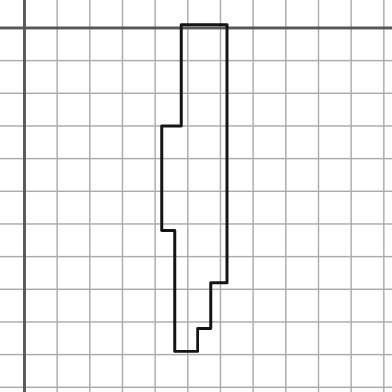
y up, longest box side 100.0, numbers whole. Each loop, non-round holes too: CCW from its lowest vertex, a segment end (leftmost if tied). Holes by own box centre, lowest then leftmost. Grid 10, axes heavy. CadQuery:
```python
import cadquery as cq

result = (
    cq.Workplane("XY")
    .moveTo(46.0, -99.0)
    .lineTo(53.0, -99.0)
    .lineTo(53.0, -92.0)
    .lineTo(57.0, -92.0)
    .lineTo(57.0, -78.0)
    .lineTo(62.0, -78.0)
    .lineTo(62.0, 1.0)
    .lineTo(48.0, 1.0)
    .lineTo(48.0, -30.0)
    .lineTo(42.0, -30.0)
    .lineTo(42.0, -62.0)
    .lineTo(46.0, -62.0)
    .close()
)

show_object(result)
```